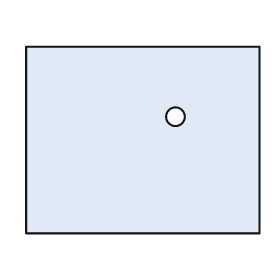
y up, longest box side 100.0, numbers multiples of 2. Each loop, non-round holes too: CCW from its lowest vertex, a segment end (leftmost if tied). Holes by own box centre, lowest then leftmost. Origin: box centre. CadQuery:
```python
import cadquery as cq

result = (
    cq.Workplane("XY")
    .moveTo(-50.0, -40.0)
    .lineTo(50.0, -40.0)
    .lineTo(50.0, 40.0)
    .lineTo(-50.0, 40.0)
    .close()
    .moveTo(14.0, 10.0)
    .circle(4.0)
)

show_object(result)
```